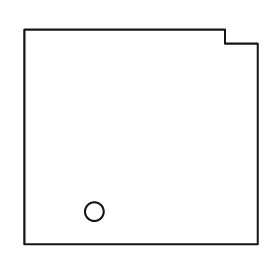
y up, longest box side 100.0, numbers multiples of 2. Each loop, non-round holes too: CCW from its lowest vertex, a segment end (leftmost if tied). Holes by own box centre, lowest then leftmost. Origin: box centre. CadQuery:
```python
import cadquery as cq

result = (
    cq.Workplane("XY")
    .moveTo(-50.0, -46.0)
    .lineTo(50.0, -46.0)
    .lineTo(50.0, 40.0)
    .lineTo(36.0, 40.0)
    .lineTo(36.0, 46.0)
    .lineTo(-50.0, 46.0)
    .close()
    .moveTo(-20.0, -32.0)
    .circle(4.0)
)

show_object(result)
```